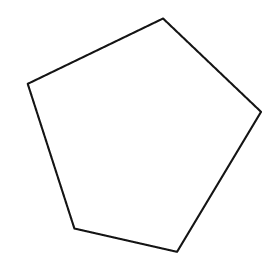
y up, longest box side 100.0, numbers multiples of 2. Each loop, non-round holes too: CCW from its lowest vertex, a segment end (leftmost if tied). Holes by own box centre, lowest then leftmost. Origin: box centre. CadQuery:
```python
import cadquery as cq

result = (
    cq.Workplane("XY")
    .moveTo(14.0, -50.0)
    .lineTo(50.0, 10.0)
    .lineTo(8.0, 50.0)
    .lineTo(-50.0, 22.0)
    .lineTo(-30.0, -40.0)
    .close()
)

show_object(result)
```